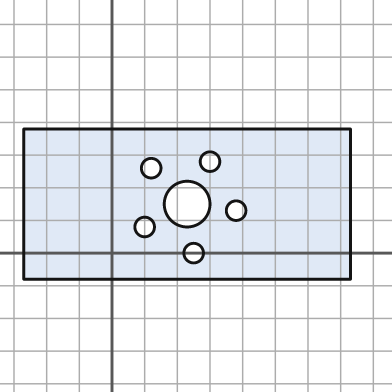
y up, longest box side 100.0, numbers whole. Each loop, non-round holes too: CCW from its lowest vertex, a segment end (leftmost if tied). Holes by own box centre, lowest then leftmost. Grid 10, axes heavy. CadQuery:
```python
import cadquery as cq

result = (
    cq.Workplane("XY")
    .moveTo(-27.0, -8.0)
    .lineTo(73.0, -8.0)
    .lineTo(73.0, 38.0)
    .lineTo(-27.0, 38.0)
    .close()
    .moveTo(25.0, 0.0)
    .circle(3.0)
    .moveTo(10.0, 8.0)
    .circle(3.0)
    .moveTo(38.0, 13.0)
    .circle(3.0)
    .moveTo(23.0, 15.0)
    .circle(7.0)
    .moveTo(12.0, 26.0)
    .circle(3.0)
    .moveTo(30.0, 28.0)
    .circle(3.0)
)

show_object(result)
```